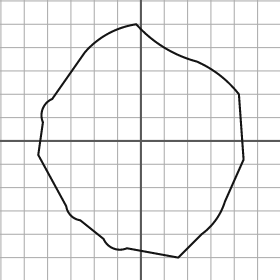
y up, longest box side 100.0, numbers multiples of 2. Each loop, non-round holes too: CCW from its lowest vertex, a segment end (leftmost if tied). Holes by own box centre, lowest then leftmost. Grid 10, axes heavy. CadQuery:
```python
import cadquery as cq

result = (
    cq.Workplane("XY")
    .moveTo(16.0, -50.0)
    .lineTo(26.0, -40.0)
    .threePointArc((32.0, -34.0), (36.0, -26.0))
    .lineTo(44.0, -8.0)
    .lineTo(42.0, 20.0)
    .threePointArc((34.0, 28.0), (24.0, 34.0))
    .threePointArc((10.0, 40.0), (-2.0, 50.0))
    .threePointArc((-14.0, 46.0), (-24.0, 38.0))
    .lineTo(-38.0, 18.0)
    .threePointArc((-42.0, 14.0), (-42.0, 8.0))
    .lineTo(-44.0, -6.0)
    .lineTo(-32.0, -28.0)
    .threePointArc((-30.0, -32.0), (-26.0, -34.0))
    .lineTo(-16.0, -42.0)
    .threePointArc((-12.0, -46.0), (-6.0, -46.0))
    .close()
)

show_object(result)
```